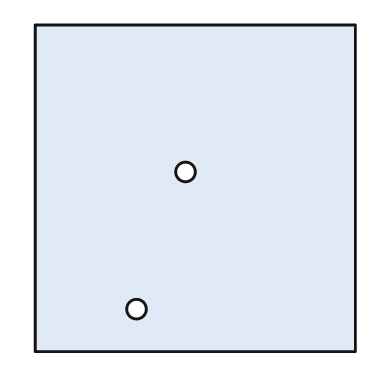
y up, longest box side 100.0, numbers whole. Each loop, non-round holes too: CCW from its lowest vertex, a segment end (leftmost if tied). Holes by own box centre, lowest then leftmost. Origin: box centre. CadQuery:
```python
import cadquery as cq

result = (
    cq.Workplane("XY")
    .moveTo(-49.0, -50.0)
    .lineTo(49.0, -50.0)
    .lineTo(49.0, 50.0)
    .lineTo(-49.0, 50.0)
    .close()
    .moveTo(-18.0, -37.0)
    .circle(3.0)
    .moveTo(-3.0, 5.0)
    .circle(3.0)
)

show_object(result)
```